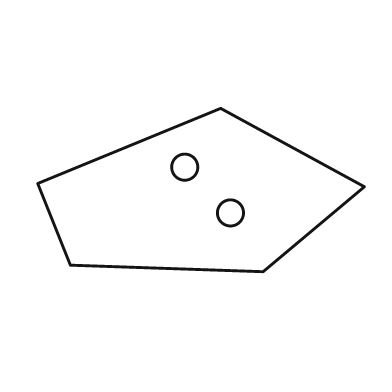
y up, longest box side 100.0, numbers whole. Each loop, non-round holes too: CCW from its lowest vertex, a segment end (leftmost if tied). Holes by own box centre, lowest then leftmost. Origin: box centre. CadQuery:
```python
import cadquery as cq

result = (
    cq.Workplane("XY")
    .moveTo(19.0, -25.0)
    .lineTo(50.0, 1.0)
    .lineTo(6.0, 25.0)
    .lineTo(-50.0, 2.0)
    .lineTo(-40.0, -23.0)
    .close()
    .moveTo(9.0, -7.0)
    .circle(4.0)
    .moveTo(-5.0, 7.0)
    .circle(4.0)
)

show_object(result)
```